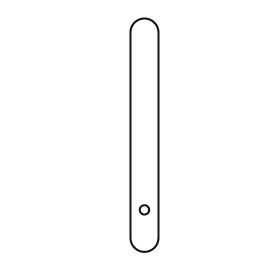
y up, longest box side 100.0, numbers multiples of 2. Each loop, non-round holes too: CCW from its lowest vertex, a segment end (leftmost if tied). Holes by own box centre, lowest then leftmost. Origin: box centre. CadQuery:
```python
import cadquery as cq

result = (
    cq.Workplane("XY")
    .moveTo(-6.0, -44.0)
    .threePointArc((0.0, -50.0), (6.0, -44.0))
    .lineTo(6.0, 44.0)
    .threePointArc((0.0, 50.0), (-6.0, 44.0))
    .close()
    .moveTo(0.0, -32.0)
    .circle(2.0)
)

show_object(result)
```